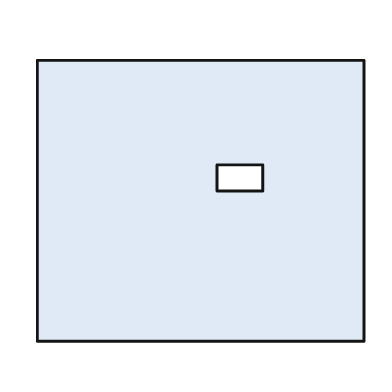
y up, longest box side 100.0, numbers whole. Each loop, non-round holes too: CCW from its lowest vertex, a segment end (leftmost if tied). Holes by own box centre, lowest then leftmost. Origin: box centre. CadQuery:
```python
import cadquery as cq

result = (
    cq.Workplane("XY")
    .moveTo(-50.0, -43.0)
    .lineTo(50.0, -43.0)
    .lineTo(50.0, 43.0)
    .lineTo(-50.0, 43.0)
    .close()
    .moveTo(5.0, 3.0)
    .lineTo(19.0, 3.0)
    .lineTo(19.0, 11.0)
    .lineTo(5.0, 11.0)
    .close()
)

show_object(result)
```